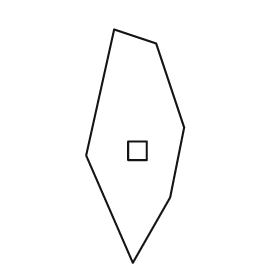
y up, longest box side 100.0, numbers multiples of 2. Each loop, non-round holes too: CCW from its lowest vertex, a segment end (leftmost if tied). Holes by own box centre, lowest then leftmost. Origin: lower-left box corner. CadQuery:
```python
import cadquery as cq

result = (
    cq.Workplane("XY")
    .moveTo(20.0, 0.0)
    .lineTo(36.0, 28.0)
    .lineTo(42.0, 58.0)
    .lineTo(30.0, 94.0)
    .lineTo(12.0, 100.0)
    .lineTo(0.0, 46.0)
    .close()
    .moveTo(18.0, 44.0)
    .lineTo(26.0, 44.0)
    .lineTo(26.0, 52.0)
    .lineTo(18.0, 52.0)
    .close()
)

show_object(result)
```